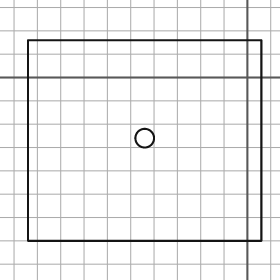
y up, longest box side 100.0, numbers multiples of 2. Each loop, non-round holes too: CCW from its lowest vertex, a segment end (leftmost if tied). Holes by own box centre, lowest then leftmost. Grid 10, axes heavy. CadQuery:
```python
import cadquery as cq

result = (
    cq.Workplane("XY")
    .moveTo(-94.0, -70.0)
    .lineTo(6.0, -70.0)
    .lineTo(6.0, 16.0)
    .lineTo(-94.0, 16.0)
    .close()
    .moveTo(-44.0, -26.0)
    .circle(4.0)
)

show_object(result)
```